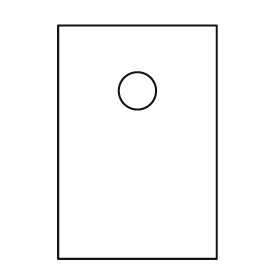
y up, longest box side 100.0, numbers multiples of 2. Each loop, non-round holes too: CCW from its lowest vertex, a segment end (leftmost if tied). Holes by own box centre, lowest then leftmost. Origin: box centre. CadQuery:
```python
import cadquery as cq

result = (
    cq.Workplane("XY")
    .moveTo(-34.0, -50.0)
    .lineTo(34.0, -50.0)
    .lineTo(34.0, 50.0)
    .lineTo(-34.0, 50.0)
    .close()
    .moveTo(0.0, 22.0)
    .circle(8.0)
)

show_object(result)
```